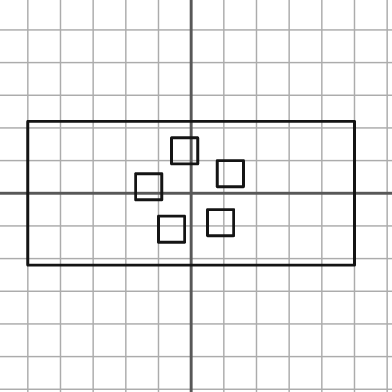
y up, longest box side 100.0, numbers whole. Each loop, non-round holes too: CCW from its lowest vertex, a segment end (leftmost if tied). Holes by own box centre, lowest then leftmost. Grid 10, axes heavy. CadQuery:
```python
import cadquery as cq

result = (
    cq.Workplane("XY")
    .moveTo(-50.0, -22.0)
    .lineTo(50.0, -22.0)
    .lineTo(50.0, 22.0)
    .lineTo(-50.0, 22.0)
    .close()
    .moveTo(-10.0, -15.0)
    .lineTo(-2.0, -15.0)
    .lineTo(-2.0, -7.0)
    .lineTo(-10.0, -7.0)
    .close()
    .moveTo(5.0, -13.0)
    .lineTo(13.0, -13.0)
    .lineTo(13.0, -5.0)
    .lineTo(5.0, -5.0)
    .close()
    .moveTo(-17.0, -2.0)
    .lineTo(-9.0, -2.0)
    .lineTo(-9.0, 6.0)
    .lineTo(-17.0, 6.0)
    .close()
    .moveTo(8.0, 2.0)
    .lineTo(16.0, 2.0)
    .lineTo(16.0, 10.0)
    .lineTo(8.0, 10.0)
    .close()
    .moveTo(-6.0, 9.0)
    .lineTo(2.0, 9.0)
    .lineTo(2.0, 17.0)
    .lineTo(-6.0, 17.0)
    .close()
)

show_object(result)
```